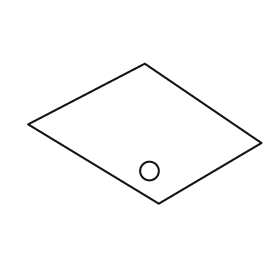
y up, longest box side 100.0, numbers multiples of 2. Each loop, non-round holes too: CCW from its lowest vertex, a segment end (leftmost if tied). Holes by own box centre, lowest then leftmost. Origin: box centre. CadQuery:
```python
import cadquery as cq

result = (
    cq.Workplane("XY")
    .moveTo(6.0, -30.0)
    .lineTo(50.0, -4.0)
    .lineTo(0.0, 30.0)
    .lineTo(-50.0, 4.0)
    .close()
    .moveTo(2.0, -16.0)
    .circle(4.0)
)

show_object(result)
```